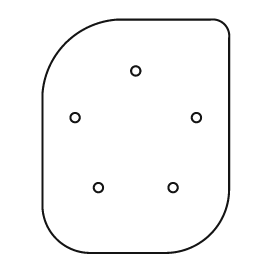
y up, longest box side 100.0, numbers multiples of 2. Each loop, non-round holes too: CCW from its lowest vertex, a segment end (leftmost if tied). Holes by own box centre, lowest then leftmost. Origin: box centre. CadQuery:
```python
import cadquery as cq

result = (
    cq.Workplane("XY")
    .moveTo(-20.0, -50.0)
    .lineTo(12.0, -50.0)
    .threePointArc((32.0, -42.0), (40.0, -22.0))
    .lineTo(40.0, 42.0)
    .threePointArc((38.0, 48.0), (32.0, 50.0))
    .lineTo(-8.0, 50.0)
    .threePointArc((-30.0, 40.0), (-40.0, 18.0))
    .lineTo(-40.0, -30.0)
    .threePointArc((-34.0, -44.0), (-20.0, -50.0))
    .close()
    .moveTo(-16.0, -22.0)
    .circle(2.0)
    .moveTo(16.0, -22.0)
    .circle(2.0)
    .moveTo(-26.0, 8.0)
    .circle(2.0)
    .moveTo(26.0, 8.0)
    .circle(2.0)
    .moveTo(0.0, 28.0)
    .circle(2.0)
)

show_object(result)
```